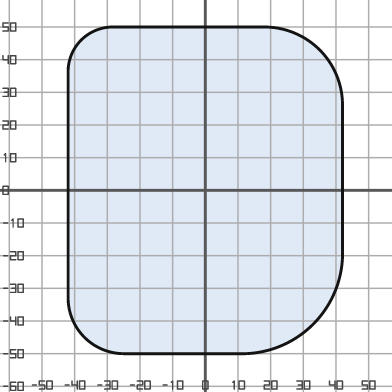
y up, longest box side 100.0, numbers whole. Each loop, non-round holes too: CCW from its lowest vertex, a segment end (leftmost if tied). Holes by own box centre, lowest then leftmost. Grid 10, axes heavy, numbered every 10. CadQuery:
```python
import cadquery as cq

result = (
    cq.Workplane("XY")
    .moveTo(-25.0, -50.0)
    .lineTo(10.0, -50.0)
    .threePointArc((33.0, -41.0), (42.0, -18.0))
    .lineTo(42.0, 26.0)
    .threePointArc((35.0, 43.0), (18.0, 50.0))
    .lineTo(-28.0, 50.0)
    .threePointArc((-38.0, 46.0), (-42.0, 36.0))
    .lineTo(-42.0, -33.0)
    .threePointArc((-37.0, -45.0), (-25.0, -50.0))
    .close()
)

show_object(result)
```